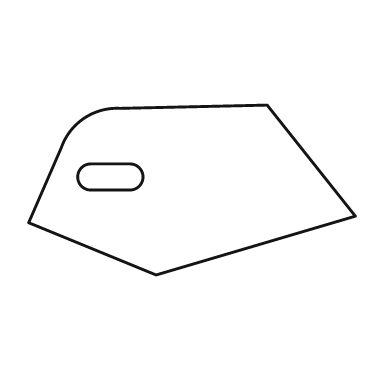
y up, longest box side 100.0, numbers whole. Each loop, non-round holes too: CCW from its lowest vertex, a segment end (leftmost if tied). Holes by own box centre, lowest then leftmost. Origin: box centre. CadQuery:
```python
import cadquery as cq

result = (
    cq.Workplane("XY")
    .moveTo(-11.0, -26.0)
    .lineTo(50.0, -8.0)
    .lineTo(23.0, 26.0)
    .lineTo(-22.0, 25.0)
    .threePointArc((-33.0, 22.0), (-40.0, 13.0))
    .lineTo(-50.0, -10.0)
    .close()
    .moveTo(-31.0, 0.0)
    .lineTo(-19.0, 0.0)
    .threePointArc((-15.0, 4.0), (-19.0, 8.0))
    .lineTo(-31.0, 8.0)
    .threePointArc((-35.0, 4.0), (-31.0, 0.0))
    .close()
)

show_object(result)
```